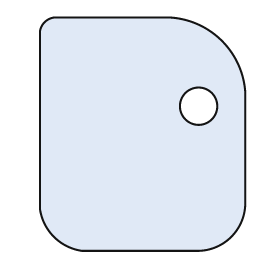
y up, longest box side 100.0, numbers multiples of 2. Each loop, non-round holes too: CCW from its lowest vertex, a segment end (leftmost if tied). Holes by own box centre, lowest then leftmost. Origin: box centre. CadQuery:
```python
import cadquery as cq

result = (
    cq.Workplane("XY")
    .moveTo(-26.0, -50.0)
    .lineTo(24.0, -50.0)
    .threePointArc((38.0, -44.0), (44.0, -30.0))
    .lineTo(44.0, 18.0)
    .threePointArc((34.0, 40.0), (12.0, 50.0))
    .lineTo(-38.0, 50.0)
    .threePointArc((-42.0, 48.0), (-44.0, 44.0))
    .lineTo(-44.0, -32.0)
    .threePointArc((-38.0, -44.0), (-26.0, -50.0))
    .close()
    .moveTo(24.0, 12.0)
    .circle(8.0)
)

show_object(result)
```